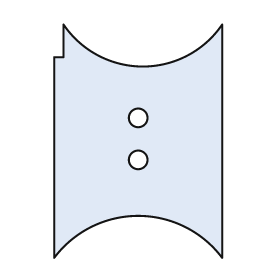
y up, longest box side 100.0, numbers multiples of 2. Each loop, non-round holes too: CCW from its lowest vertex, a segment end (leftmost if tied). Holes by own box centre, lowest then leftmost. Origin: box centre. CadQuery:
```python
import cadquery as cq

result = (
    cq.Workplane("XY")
    .moveTo(-36.0, -50.0)
    .threePointArc((0.0, -32.0), (36.0, -50.0))
    .lineTo(36.0, 50.0)
    .threePointArc((2.0, 32.0), (-32.0, 50.0))
    .lineTo(-32.0, 36.0)
    .lineTo(-36.0, 36.0)
    .close()
    .moveTo(0.0, -8.0)
    .circle(4.0)
    .moveTo(0.0, 10.0)
    .circle(4.0)
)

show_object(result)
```